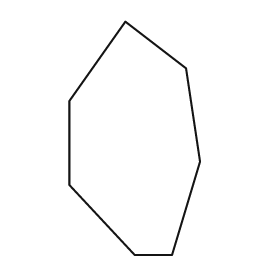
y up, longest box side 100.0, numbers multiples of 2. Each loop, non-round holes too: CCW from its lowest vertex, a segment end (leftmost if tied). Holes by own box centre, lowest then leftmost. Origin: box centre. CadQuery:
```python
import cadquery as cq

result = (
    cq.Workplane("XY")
    .moveTo(0.0, -50.0)
    .lineTo(16.0, -50.0)
    .lineTo(28.0, -10.0)
    .lineTo(22.0, 30.0)
    .lineTo(-4.0, 50.0)
    .lineTo(-28.0, 16.0)
    .lineTo(-28.0, -20.0)
    .close()
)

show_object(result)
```